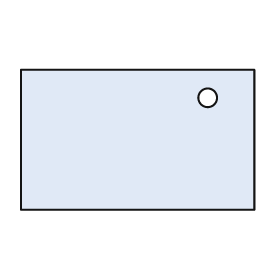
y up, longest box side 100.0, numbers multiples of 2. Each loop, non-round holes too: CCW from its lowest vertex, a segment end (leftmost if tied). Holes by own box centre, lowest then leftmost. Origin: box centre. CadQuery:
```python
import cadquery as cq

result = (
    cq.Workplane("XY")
    .moveTo(-50.0, -30.0)
    .lineTo(50.0, -30.0)
    .lineTo(50.0, 30.0)
    .lineTo(-50.0, 30.0)
    .close()
    .moveTo(30.0, 18.0)
    .circle(4.0)
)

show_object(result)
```